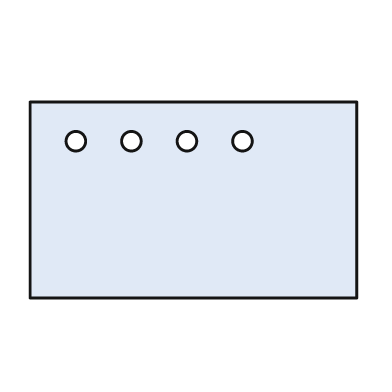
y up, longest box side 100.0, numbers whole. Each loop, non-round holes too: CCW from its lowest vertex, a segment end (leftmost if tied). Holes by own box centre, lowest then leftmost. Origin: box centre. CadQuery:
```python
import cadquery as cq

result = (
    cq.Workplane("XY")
    .moveTo(-50.0, -30.0)
    .lineTo(50.0, -30.0)
    .lineTo(50.0, 30.0)
    .lineTo(-50.0, 30.0)
    .close()
    .moveTo(-36.0, 18.0)
    .circle(3.0)
    .moveTo(-19.0, 18.0)
    .circle(3.0)
    .moveTo(-2.0, 18.0)
    .circle(3.0)
    .moveTo(15.0, 18.0)
    .circle(3.0)
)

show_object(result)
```